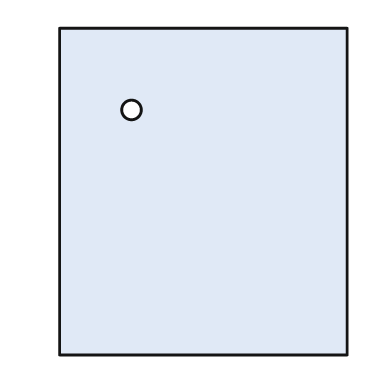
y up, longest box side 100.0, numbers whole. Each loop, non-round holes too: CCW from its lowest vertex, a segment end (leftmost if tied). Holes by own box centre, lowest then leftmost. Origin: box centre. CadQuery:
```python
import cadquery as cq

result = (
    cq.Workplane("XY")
    .moveTo(-44.0, -50.0)
    .lineTo(44.0, -50.0)
    .lineTo(44.0, 50.0)
    .lineTo(-44.0, 50.0)
    .close()
    .moveTo(-22.0, 25.0)
    .circle(3.0)
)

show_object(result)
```